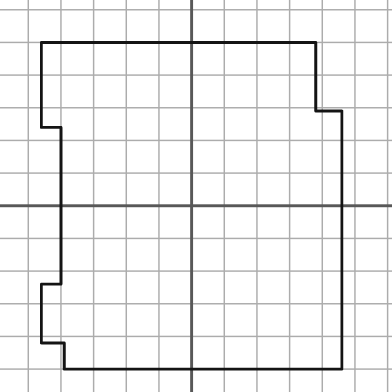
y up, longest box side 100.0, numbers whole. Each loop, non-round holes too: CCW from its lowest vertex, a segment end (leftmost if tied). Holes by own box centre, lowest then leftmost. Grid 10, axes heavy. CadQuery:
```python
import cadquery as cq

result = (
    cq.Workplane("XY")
    .moveTo(-39.0, -50.0)
    .lineTo(46.0, -50.0)
    .lineTo(46.0, 29.0)
    .lineTo(38.0, 29.0)
    .lineTo(38.0, 50.0)
    .lineTo(-46.0, 50.0)
    .lineTo(-46.0, 24.0)
    .lineTo(-40.0, 24.0)
    .lineTo(-40.0, -24.0)
    .lineTo(-46.0, -24.0)
    .lineTo(-46.0, -42.0)
    .lineTo(-39.0, -42.0)
    .close()
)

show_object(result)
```